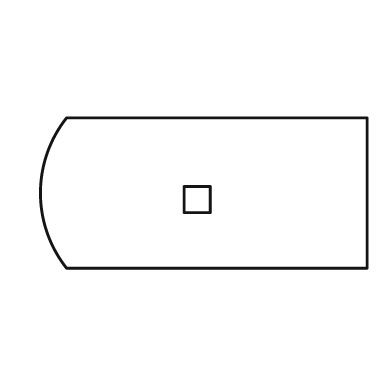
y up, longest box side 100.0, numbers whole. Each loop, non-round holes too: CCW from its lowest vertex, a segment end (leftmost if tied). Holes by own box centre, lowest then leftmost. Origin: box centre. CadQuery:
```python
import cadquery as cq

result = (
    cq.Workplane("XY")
    .moveTo(-42.0, -23.0)
    .lineTo(50.0, -23.0)
    .lineTo(50.0, 23.0)
    .lineTo(-42.0, 23.0)
    .threePointArc((-50.0, 0.0), (-42.0, -23.0))
    .close()
    .moveTo(-6.0, -6.0)
    .lineTo(2.0, -6.0)
    .lineTo(2.0, 2.0)
    .lineTo(-6.0, 2.0)
    .close()
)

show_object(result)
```